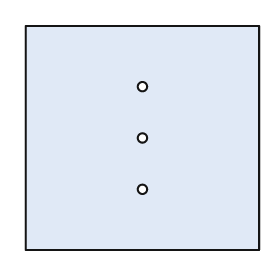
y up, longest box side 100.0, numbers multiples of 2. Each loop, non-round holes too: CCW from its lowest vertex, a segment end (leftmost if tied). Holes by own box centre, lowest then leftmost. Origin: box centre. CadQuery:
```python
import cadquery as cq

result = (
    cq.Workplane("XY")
    .moveTo(-50.0, -48.0)
    .lineTo(50.0, -48.0)
    .lineTo(50.0, 48.0)
    .lineTo(-50.0, 48.0)
    .close()
    .moveTo(0.0, -22.0)
    .circle(2.0)
    .moveTo(0.0, 0.0)
    .circle(2.0)
    .moveTo(0.0, 22.0)
    .circle(2.0)
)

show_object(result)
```